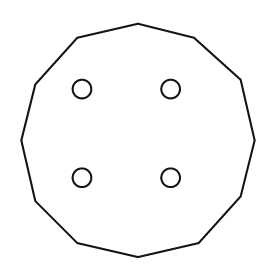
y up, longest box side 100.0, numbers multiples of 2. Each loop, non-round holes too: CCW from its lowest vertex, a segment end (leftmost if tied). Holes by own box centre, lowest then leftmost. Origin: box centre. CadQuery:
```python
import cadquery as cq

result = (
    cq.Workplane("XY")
    .moveTo(0.0, -50.0)
    .lineTo(26.0, -44.0)
    .lineTo(44.0, -24.0)
    .lineTo(50.0, 0.0)
    .lineTo(44.0, 26.0)
    .lineTo(24.0, 44.0)
    .lineTo(0.0, 50.0)
    .lineTo(-26.0, 44.0)
    .lineTo(-44.0, 24.0)
    .lineTo(-50.0, 0.0)
    .lineTo(-44.0, -26.0)
    .lineTo(-26.0, -44.0)
    .close()
    .moveTo(-24.0, -16.0)
    .circle(4.0)
    .moveTo(14.0, -16.0)
    .circle(4.0)
    .moveTo(-24.0, 22.0)
    .circle(4.0)
    .moveTo(14.0, 22.0)
    .circle(4.0)
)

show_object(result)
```